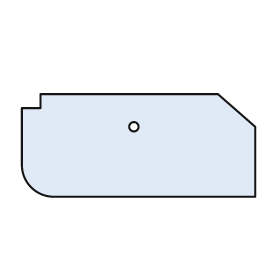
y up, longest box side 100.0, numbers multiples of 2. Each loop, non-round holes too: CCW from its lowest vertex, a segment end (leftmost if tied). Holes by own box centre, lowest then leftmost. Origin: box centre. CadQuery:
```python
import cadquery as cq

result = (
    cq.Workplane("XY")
    .moveTo(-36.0, -22.0)
    .lineTo(50.0, -22.0)
    .lineTo(50.0, 8.0)
    .lineTo(34.0, 22.0)
    .lineTo(-42.0, 22.0)
    .lineTo(-42.0, 16.0)
    .lineTo(-50.0, 16.0)
    .lineTo(-50.0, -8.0)
    .threePointArc((-46.0, -18.0), (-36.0, -22.0))
    .close()
    .moveTo(-2.0, 8.0)
    .circle(2.0)
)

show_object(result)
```